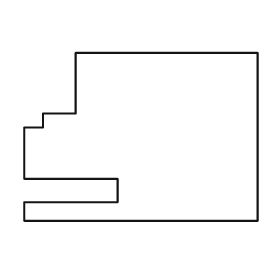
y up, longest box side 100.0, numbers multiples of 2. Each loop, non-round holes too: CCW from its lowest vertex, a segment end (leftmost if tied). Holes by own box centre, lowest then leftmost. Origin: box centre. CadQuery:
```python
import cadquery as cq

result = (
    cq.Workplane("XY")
    .moveTo(-50.0, -36.0)
    .lineTo(50.0, -36.0)
    .lineTo(50.0, 36.0)
    .lineTo(-28.0, 36.0)
    .lineTo(-28.0, 10.0)
    .lineTo(-42.0, 10.0)
    .lineTo(-42.0, 4.0)
    .lineTo(-50.0, 4.0)
    .lineTo(-50.0, -18.0)
    .lineTo(-10.0, -18.0)
    .lineTo(-10.0, -28.0)
    .lineTo(-50.0, -28.0)
    .close()
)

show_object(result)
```